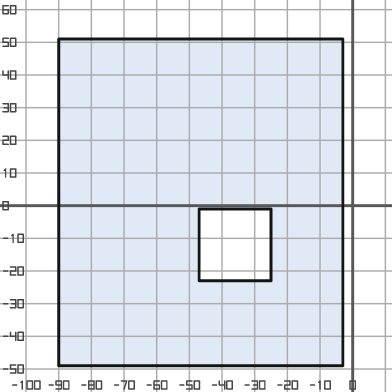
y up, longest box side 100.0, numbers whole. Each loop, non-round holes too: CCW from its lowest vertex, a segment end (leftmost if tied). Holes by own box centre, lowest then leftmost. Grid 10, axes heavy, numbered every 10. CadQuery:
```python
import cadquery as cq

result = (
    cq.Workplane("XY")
    .moveTo(-90.0, -49.0)
    .lineTo(-3.0, -49.0)
    .lineTo(-3.0, 51.0)
    .lineTo(-90.0, 51.0)
    .close()
    .moveTo(-47.0, -23.0)
    .lineTo(-25.0, -23.0)
    .lineTo(-25.0, -1.0)
    .lineTo(-47.0, -1.0)
    .close()
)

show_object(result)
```